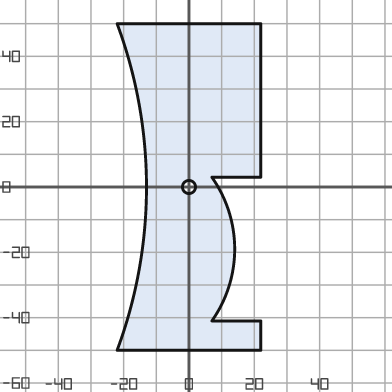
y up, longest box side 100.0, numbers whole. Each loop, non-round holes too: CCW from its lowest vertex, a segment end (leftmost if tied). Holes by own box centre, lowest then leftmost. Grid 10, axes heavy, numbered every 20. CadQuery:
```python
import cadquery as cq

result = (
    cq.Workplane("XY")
    .moveTo(-22.0, -50.0)
    .lineTo(22.0, -50.0)
    .lineTo(22.0, -41.0)
    .lineTo(7.0, -41.0)
    .threePointArc((14.0, -19.0), (7.0, 3.0))
    .lineTo(22.0, 3.0)
    .lineTo(22.0, 50.0)
    .lineTo(-22.0, 50.0)
    .threePointArc((-13.0, 0.0), (-22.0, -50.0))
    .close()
    .moveTo(0.0, 0.0)
    .circle(2.0)
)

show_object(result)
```